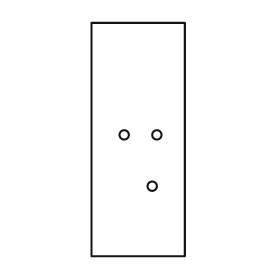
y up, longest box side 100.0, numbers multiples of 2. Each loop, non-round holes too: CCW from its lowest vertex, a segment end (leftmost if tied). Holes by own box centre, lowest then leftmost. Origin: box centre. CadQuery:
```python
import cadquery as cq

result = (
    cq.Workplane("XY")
    .moveTo(-20.0, -50.0)
    .lineTo(20.0, -50.0)
    .lineTo(20.0, 50.0)
    .lineTo(-20.0, 50.0)
    .close()
    .moveTo(6.0, -20.0)
    .circle(2.0)
    .moveTo(-6.0, 2.0)
    .circle(2.0)
    .moveTo(8.0, 2.0)
    .circle(2.0)
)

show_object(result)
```